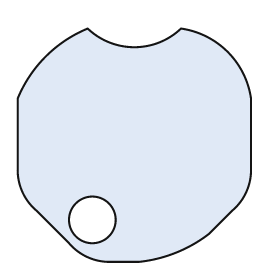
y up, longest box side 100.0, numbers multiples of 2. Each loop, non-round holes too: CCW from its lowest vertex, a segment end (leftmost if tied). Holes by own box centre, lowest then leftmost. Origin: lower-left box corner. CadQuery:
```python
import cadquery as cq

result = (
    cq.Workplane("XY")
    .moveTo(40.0, 0.0)
    .lineTo(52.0, 0.0)
    .threePointArc((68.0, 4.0), (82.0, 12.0))
    .lineTo(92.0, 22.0)
    .threePointArc((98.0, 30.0), (100.0, 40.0))
    .lineTo(100.0, 70.0)
    .threePointArc((90.0, 90.0), (70.0, 100.0))
    .threePointArc((50.0, 92.0), (30.0, 100.0))
    .threePointArc((12.0, 88.0), (0.0, 70.0))
    .lineTo(0.0, 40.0)
    .threePointArc((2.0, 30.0), (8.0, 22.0))
    .lineTo(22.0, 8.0)
    .threePointArc((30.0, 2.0), (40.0, 0.0))
    .close()
    .moveTo(32.0, 18.0)
    .circle(10.0)
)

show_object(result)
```